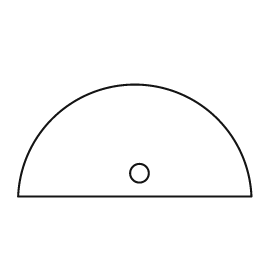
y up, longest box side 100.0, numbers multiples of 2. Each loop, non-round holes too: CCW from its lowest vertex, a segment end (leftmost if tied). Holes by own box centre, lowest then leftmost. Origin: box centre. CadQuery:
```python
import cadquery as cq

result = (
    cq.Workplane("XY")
    .moveTo(-50.0, -24.0)
    .lineTo(50.0, -24.0)
    .threePointArc((0.0, 24.0), (-50.0, -24.0))
    .close()
    .moveTo(2.0, -14.0)
    .circle(4.0)
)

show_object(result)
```